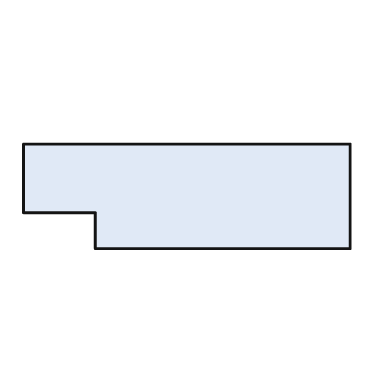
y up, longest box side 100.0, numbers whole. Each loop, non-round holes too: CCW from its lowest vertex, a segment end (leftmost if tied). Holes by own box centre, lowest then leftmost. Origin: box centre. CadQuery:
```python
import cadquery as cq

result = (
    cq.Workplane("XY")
    .moveTo(-28.0, -16.0)
    .lineTo(50.0, -16.0)
    .lineTo(50.0, 16.0)
    .lineTo(-50.0, 16.0)
    .lineTo(-50.0, -5.0)
    .lineTo(-28.0, -5.0)
    .close()
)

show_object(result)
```